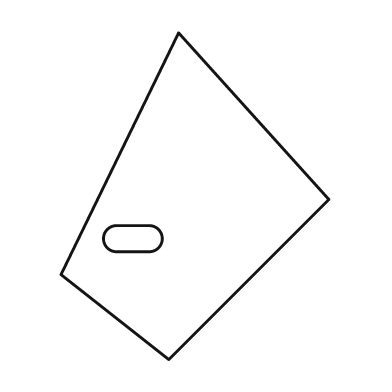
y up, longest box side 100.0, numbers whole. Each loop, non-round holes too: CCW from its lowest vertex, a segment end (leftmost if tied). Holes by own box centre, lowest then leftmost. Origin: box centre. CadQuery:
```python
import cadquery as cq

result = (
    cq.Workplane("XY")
    .moveTo(-8.0, -50.0)
    .lineTo(41.0, -1.0)
    .lineTo(-5.0, 50.0)
    .lineTo(-41.0, -24.0)
    .close()
    .moveTo(-24.0, -17.0)
    .lineTo(-14.0, -17.0)
    .threePointArc((-10.0, -13.0), (-14.0, -9.0))
    .lineTo(-24.0, -9.0)
    .threePointArc((-28.0, -13.0), (-24.0, -17.0))
    .close()
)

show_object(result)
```